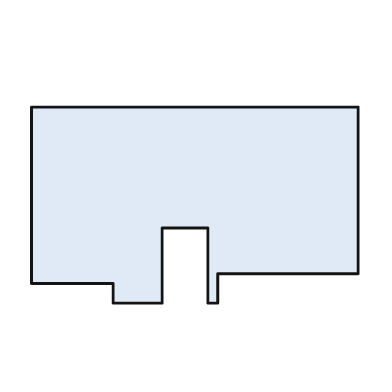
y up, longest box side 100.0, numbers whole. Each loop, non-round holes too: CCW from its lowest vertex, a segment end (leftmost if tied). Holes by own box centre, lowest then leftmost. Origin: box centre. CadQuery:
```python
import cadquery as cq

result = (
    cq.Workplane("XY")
    .moveTo(-25.0, -30.0)
    .lineTo(-10.0, -30.0)
    .lineTo(-10.0, -7.0)
    .lineTo(4.0, -7.0)
    .lineTo(4.0, -30.0)
    .lineTo(7.0, -30.0)
    .lineTo(7.0, -21.0)
    .lineTo(50.0, -21.0)
    .lineTo(50.0, 30.0)
    .lineTo(-50.0, 30.0)
    .lineTo(-50.0, -24.0)
    .lineTo(-25.0, -24.0)
    .close()
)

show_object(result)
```